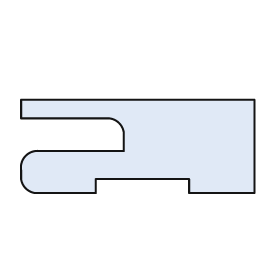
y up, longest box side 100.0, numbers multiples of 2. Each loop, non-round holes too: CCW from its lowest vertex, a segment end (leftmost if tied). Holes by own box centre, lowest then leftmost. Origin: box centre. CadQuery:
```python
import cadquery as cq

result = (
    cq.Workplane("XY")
    .moveTo(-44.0, -20.0)
    .lineTo(-18.0, -20.0)
    .lineTo(-18.0, -14.0)
    .lineTo(22.0, -14.0)
    .lineTo(22.0, -20.0)
    .lineTo(50.0, -20.0)
    .lineTo(50.0, 20.0)
    .lineTo(-50.0, 20.0)
    .lineTo(-50.0, 12.0)
    .lineTo(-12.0, 12.0)
    .threePointArc((-8.0, 10.0), (-6.0, 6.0))
    .lineTo(-6.0, -2.0)
    .lineTo(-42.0, -2.0)
    .threePointArc((-48.0, -4.0), (-50.0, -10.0))
    .lineTo(-50.0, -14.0)
    .threePointArc((-48.0, -18.0), (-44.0, -20.0))
    .close()
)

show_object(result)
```